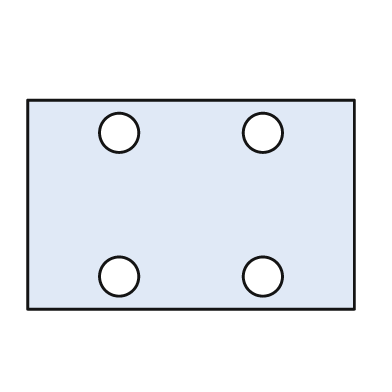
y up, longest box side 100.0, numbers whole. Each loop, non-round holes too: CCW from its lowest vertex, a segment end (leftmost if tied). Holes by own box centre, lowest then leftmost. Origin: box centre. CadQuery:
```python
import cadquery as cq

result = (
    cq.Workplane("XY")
    .moveTo(-50.0, -32.0)
    .lineTo(50.0, -32.0)
    .lineTo(50.0, 32.0)
    .lineTo(-50.0, 32.0)
    .close()
    .moveTo(-22.0, -22.0)
    .circle(6.0)
    .moveTo(22.0, -22.0)
    .circle(6.0)
    .moveTo(-22.0, 22.0)
    .circle(6.0)
    .moveTo(22.0, 22.0)
    .circle(6.0)
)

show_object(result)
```